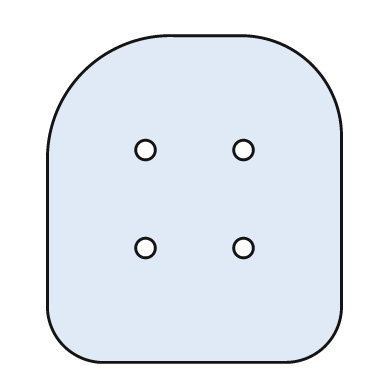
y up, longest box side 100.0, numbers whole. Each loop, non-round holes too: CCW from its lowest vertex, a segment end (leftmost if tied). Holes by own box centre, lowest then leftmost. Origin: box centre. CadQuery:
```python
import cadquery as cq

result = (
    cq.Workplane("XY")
    .moveTo(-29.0, -50.0)
    .lineTo(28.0, -50.0)
    .threePointArc((40.0, -45.0), (45.0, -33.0))
    .lineTo(45.0, 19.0)
    .threePointArc((36.0, 41.0), (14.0, 50.0))
    .lineTo(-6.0, 50.0)
    .threePointArc((-34.0, 39.0), (-45.0, 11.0))
    .lineTo(-45.0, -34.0)
    .threePointArc((-40.0, -45.0), (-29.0, -50.0))
    .close()
    .moveTo(-15.0, -15.0)
    .circle(3.0)
    .moveTo(15.0, -15.0)
    .circle(3.0)
    .moveTo(-15.0, 15.0)
    .circle(3.0)
    .moveTo(15.0, 15.0)
    .circle(3.0)
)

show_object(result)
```